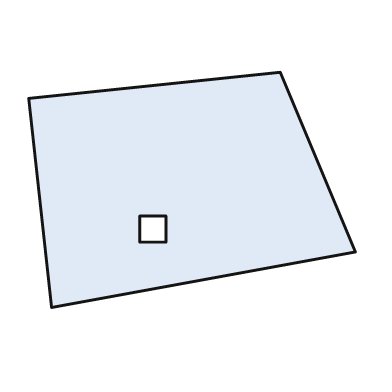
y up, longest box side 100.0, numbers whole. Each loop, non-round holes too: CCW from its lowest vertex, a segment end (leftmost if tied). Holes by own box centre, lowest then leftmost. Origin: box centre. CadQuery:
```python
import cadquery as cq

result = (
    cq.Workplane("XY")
    .moveTo(-43.0, -36.0)
    .lineTo(50.0, -19.0)
    .lineTo(27.0, 36.0)
    .lineTo(-50.0, 28.0)
    .close()
    .moveTo(-16.0, -16.0)
    .lineTo(-8.0, -16.0)
    .lineTo(-8.0, -8.0)
    .lineTo(-16.0, -8.0)
    .close()
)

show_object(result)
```